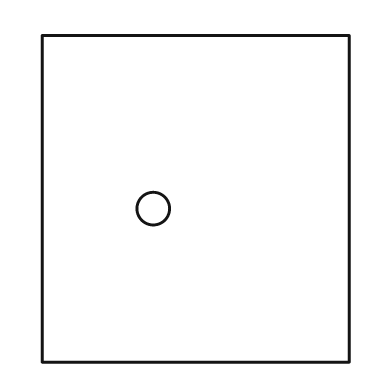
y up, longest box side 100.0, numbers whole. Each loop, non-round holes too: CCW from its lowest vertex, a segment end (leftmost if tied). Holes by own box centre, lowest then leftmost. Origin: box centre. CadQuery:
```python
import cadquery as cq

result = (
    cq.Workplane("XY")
    .moveTo(-47.0, -50.0)
    .lineTo(47.0, -50.0)
    .lineTo(47.0, 50.0)
    .lineTo(-47.0, 50.0)
    .close()
    .moveTo(-13.0, -3.0)
    .circle(5.0)
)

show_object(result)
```